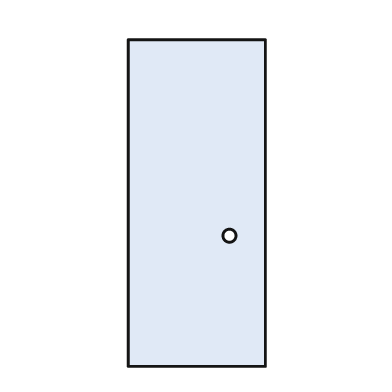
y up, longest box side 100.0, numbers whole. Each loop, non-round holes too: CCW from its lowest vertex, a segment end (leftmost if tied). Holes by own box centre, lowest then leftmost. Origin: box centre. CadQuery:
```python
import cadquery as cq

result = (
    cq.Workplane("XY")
    .moveTo(-21.0, -50.0)
    .lineTo(21.0, -50.0)
    .lineTo(21.0, 50.0)
    .lineTo(-21.0, 50.0)
    .close()
    .moveTo(10.0, -10.0)
    .circle(2.0)
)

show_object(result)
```